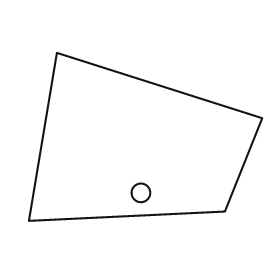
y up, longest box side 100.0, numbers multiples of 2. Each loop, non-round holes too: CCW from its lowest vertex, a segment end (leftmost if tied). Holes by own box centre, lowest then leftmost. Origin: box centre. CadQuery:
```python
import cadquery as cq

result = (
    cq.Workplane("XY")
    .moveTo(-50.0, -36.0)
    .lineTo(34.0, -32.0)
    .lineTo(50.0, 8.0)
    .lineTo(-38.0, 36.0)
    .close()
    .moveTo(-2.0, -24.0)
    .circle(4.0)
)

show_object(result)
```